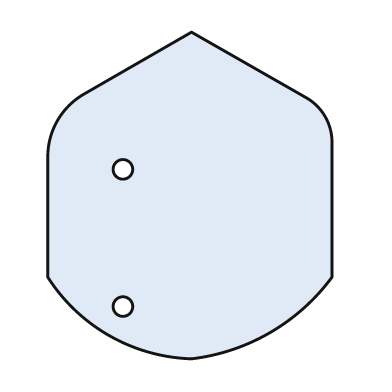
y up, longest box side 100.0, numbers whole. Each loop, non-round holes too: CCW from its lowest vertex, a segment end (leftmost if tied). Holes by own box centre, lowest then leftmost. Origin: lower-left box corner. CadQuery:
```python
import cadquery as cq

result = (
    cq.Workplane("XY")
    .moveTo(44.0, 0.0)
    .threePointArc((68.0, 8.0), (87.0, 25.0))
    .lineTo(87.0, 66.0)
    .threePointArc((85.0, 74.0), (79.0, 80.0))
    .lineTo(44.0, 100.0)
    .lineTo(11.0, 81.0)
    .threePointArc((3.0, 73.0), (0.0, 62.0))
    .lineTo(0.0, 25.0)
    .threePointArc((19.0, 7.0), (44.0, 0.0))
    .close()
    .moveTo(23.0, 16.0)
    .circle(3.0)
    .moveTo(23.0, 58.0)
    .circle(3.0)
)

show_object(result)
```